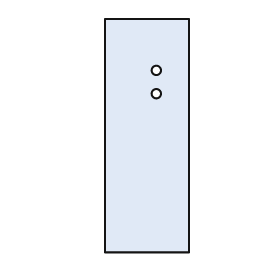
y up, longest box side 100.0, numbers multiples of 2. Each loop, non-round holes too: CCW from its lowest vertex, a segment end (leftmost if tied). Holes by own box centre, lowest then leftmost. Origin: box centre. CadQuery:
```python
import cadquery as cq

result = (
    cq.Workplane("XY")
    .moveTo(-18.0, -50.0)
    .lineTo(18.0, -50.0)
    .lineTo(18.0, 50.0)
    .lineTo(-18.0, 50.0)
    .close()
    .moveTo(4.0, 18.0)
    .circle(2.0)
    .moveTo(4.0, 28.0)
    .circle(2.0)
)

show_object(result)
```